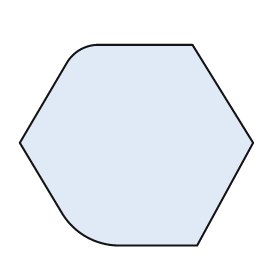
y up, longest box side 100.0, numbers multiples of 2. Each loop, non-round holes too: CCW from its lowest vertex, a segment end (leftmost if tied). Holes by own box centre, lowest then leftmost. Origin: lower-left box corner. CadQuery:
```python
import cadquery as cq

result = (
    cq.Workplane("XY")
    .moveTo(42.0, 0.0)
    .lineTo(76.0, 0.0)
    .lineTo(100.0, 44.0)
    .lineTo(74.0, 86.0)
    .lineTo(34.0, 86.0)
    .threePointArc((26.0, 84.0), (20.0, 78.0))
    .lineTo(0.0, 44.0)
    .lineTo(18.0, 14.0)
    .threePointArc((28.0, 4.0), (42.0, 0.0))
    .close()
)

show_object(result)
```